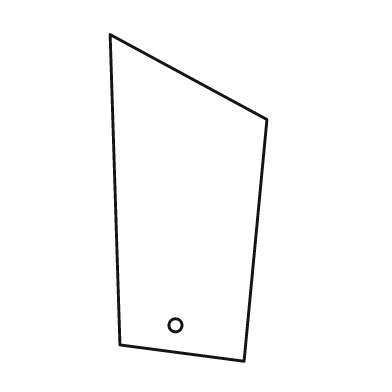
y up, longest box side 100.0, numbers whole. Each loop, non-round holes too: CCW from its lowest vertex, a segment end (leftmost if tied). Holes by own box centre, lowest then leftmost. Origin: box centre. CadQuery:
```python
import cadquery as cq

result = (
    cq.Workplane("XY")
    .moveTo(17.0, -50.0)
    .lineTo(24.0, 24.0)
    .lineTo(-24.0, 50.0)
    .lineTo(-21.0, -45.0)
    .close()
    .moveTo(-4.0, -39.0)
    .circle(2.0)
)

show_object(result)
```